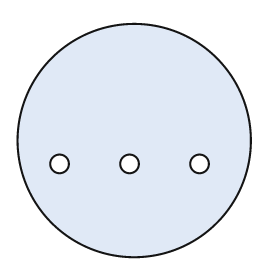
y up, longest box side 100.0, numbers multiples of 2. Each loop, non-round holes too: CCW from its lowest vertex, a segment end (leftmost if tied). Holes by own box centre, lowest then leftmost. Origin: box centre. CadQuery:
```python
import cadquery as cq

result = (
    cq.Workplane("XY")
    .moveTo(0.0, 0.0)
    .circle(50.0)
    .moveTo(-32.0, -10.0)
    .circle(4.0)
    .moveTo(-2.0, -10.0)
    .circle(4.0)
    .moveTo(28.0, -10.0)
    .circle(4.0)
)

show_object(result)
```